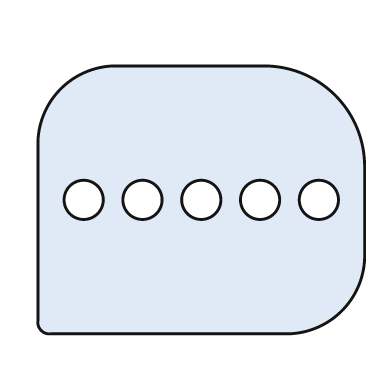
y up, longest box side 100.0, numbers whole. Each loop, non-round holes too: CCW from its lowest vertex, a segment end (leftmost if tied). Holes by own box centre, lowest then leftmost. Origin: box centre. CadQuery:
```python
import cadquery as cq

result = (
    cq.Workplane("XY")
    .moveTo(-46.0, -41.0)
    .lineTo(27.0, -41.0)
    .threePointArc((43.0, -34.0), (50.0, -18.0))
    .lineTo(50.0, 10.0)
    .threePointArc((41.0, 32.0), (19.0, 41.0))
    .lineTo(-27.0, 41.0)
    .threePointArc((-43.0, 34.0), (-50.0, 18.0))
    .lineTo(-50.0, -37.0)
    .threePointArc((-49.0, -40.0), (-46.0, -41.0))
    .close()
    .moveTo(-36.0, 0.0)
    .circle(6.0)
    .moveTo(-18.0, 0.0)
    .circle(6.0)
    .moveTo(0.0, 0.0)
    .circle(6.0)
    .moveTo(18.0, 0.0)
    .circle(6.0)
    .moveTo(36.0, 0.0)
    .circle(6.0)
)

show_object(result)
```